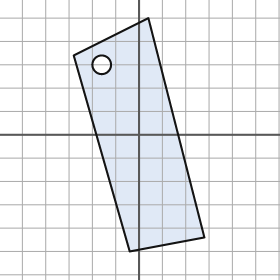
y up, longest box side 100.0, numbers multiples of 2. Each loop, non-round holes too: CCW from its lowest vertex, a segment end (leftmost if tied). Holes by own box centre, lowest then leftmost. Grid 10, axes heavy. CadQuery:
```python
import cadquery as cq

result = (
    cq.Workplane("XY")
    .moveTo(-4.0, -50.0)
    .lineTo(28.0, -44.0)
    .lineTo(4.0, 50.0)
    .lineTo(-28.0, 34.0)
    .close()
    .moveTo(-16.0, 30.0)
    .circle(4.0)
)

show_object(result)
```